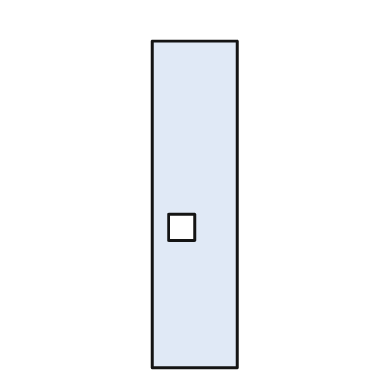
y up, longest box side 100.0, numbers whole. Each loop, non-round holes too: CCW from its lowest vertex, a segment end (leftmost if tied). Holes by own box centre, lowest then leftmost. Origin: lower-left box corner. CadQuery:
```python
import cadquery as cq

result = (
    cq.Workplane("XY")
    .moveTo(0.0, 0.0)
    .lineTo(26.0, 0.0)
    .lineTo(26.0, 100.0)
    .lineTo(0.0, 100.0)
    .close()
    .moveTo(5.0, 39.0)
    .lineTo(13.0, 39.0)
    .lineTo(13.0, 47.0)
    .lineTo(5.0, 47.0)
    .close()
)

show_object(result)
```